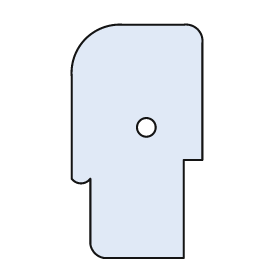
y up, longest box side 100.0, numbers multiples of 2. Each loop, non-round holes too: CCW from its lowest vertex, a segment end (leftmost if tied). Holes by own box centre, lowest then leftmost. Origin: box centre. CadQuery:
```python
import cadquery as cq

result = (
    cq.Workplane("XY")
    .moveTo(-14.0, -50.0)
    .lineTo(20.0, -50.0)
    .lineTo(20.0, -8.0)
    .lineTo(28.0, -8.0)
    .lineTo(28.0, 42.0)
    .threePointArc((26.0, 48.0), (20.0, 50.0))
    .lineTo(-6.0, 50.0)
    .threePointArc((-22.0, 44.0), (-28.0, 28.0))
    .lineTo(-28.0, -16.0)
    .threePointArc((-24.0, -18.0), (-20.0, -16.0))
    .lineTo(-20.0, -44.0)
    .threePointArc((-18.0, -48.0), (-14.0, -50.0))
    .close()
    .moveTo(4.0, 6.0)
    .circle(4.0)
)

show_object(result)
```